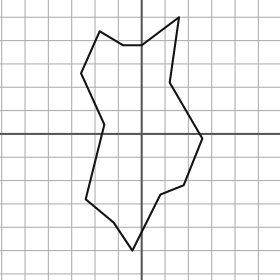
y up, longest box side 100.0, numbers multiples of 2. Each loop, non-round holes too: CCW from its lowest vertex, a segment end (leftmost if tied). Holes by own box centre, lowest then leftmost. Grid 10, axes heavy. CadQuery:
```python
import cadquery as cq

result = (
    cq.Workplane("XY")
    .moveTo(-4.0, -50.0)
    .lineTo(8.0, -26.0)
    .lineTo(18.0, -22.0)
    .lineTo(26.0, -2.0)
    .lineTo(12.0, 22.0)
    .lineTo(16.0, 50.0)
    .lineTo(0.0, 38.0)
    .lineTo(-8.0, 38.0)
    .lineTo(-18.0, 44.0)
    .lineTo(-26.0, 26.0)
    .lineTo(-16.0, 4.0)
    .lineTo(-24.0, -28.0)
    .lineTo(-12.0, -38.0)
    .close()
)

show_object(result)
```